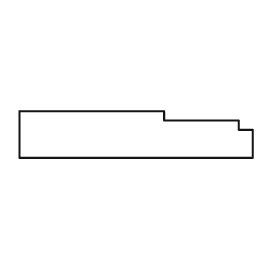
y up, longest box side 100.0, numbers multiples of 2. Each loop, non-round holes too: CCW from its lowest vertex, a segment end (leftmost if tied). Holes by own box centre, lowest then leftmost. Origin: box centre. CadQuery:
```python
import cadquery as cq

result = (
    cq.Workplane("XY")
    .moveTo(-50.0, -10.0)
    .lineTo(50.0, -10.0)
    .lineTo(50.0, 2.0)
    .lineTo(44.0, 2.0)
    .lineTo(44.0, 6.0)
    .lineTo(12.0, 6.0)
    .lineTo(12.0, 10.0)
    .lineTo(-50.0, 10.0)
    .close()
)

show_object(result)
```